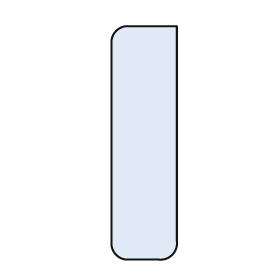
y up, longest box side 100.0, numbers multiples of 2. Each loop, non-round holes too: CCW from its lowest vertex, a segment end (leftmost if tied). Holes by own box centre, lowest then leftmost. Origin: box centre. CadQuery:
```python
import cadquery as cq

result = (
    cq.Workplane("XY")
    .moveTo(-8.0, -50.0)
    .lineTo(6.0, -50.0)
    .threePointArc((12.0, -48.0), (14.0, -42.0))
    .lineTo(14.0, 50.0)
    .lineTo(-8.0, 50.0)
    .threePointArc((-12.0, 48.0), (-14.0, 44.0))
    .lineTo(-14.0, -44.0)
    .threePointArc((-12.0, -48.0), (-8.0, -50.0))
    .close()
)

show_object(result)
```